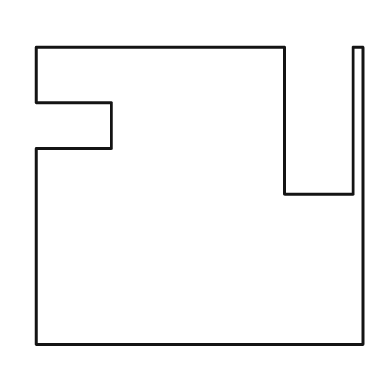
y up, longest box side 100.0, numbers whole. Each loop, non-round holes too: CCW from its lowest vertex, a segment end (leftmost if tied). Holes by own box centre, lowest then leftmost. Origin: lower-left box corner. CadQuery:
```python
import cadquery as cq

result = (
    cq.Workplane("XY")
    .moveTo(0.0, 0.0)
    .lineTo(100.0, 0.0)
    .lineTo(100.0, 91.0)
    .lineTo(97.0, 91.0)
    .lineTo(97.0, 46.0)
    .lineTo(76.0, 46.0)
    .lineTo(76.0, 91.0)
    .lineTo(0.0, 91.0)
    .lineTo(0.0, 74.0)
    .lineTo(23.0, 74.0)
    .lineTo(23.0, 60.0)
    .lineTo(0.0, 60.0)
    .close()
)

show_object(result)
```